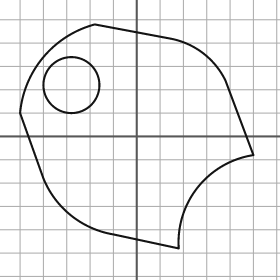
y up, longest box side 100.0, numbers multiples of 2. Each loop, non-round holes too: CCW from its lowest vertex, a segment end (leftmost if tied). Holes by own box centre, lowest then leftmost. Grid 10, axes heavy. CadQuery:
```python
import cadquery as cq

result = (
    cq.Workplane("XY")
    .moveTo(18.0, -48.0)
    .threePointArc((26.0, -22.0), (50.0, -8.0))
    .lineTo(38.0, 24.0)
    .threePointArc((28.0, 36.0), (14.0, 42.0))
    .lineTo(-18.0, 48.0)
    .threePointArc((-40.0, 34.0), (-50.0, 10.0))
    .lineTo(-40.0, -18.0)
    .threePointArc((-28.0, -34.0), (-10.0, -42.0))
    .close()
    .moveTo(-28.0, 22.0)
    .circle(12.0)
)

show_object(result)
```